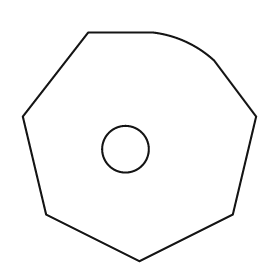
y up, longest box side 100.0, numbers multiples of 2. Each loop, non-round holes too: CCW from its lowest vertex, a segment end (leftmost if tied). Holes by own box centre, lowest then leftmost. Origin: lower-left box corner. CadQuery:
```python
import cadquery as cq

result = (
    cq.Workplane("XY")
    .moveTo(50.0, 0.0)
    .lineTo(90.0, 20.0)
    .lineTo(100.0, 62.0)
    .lineTo(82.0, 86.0)
    .threePointArc((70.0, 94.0), (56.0, 98.0))
    .lineTo(28.0, 98.0)
    .lineTo(0.0, 62.0)
    .lineTo(10.0, 20.0)
    .close()
    .moveTo(44.0, 48.0)
    .circle(10.0)
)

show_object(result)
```